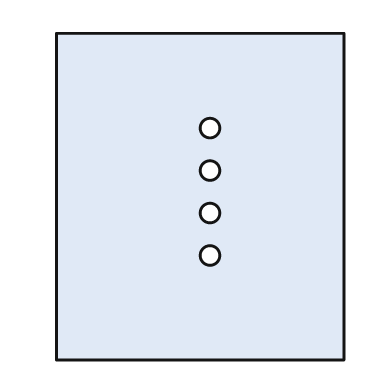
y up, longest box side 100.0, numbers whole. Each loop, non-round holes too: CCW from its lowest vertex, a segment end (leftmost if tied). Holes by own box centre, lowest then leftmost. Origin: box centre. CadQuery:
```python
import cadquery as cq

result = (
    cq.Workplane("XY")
    .moveTo(-44.0, -50.0)
    .lineTo(44.0, -50.0)
    .lineTo(44.0, 50.0)
    .lineTo(-44.0, 50.0)
    .close()
    .moveTo(3.0, -18.0)
    .circle(3.0)
    .moveTo(3.0, -5.0)
    .circle(3.0)
    .moveTo(3.0, 8.0)
    .circle(3.0)
    .moveTo(3.0, 21.0)
    .circle(3.0)
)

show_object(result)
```